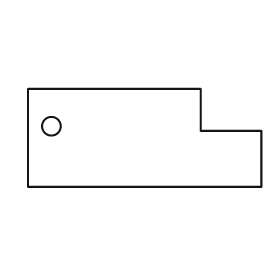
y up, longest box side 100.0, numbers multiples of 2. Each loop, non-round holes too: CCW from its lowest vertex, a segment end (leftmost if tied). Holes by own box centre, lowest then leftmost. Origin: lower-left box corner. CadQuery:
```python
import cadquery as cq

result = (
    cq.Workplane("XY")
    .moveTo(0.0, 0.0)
    .lineTo(100.0, 0.0)
    .lineTo(100.0, 24.0)
    .lineTo(74.0, 24.0)
    .lineTo(74.0, 42.0)
    .lineTo(0.0, 42.0)
    .close()
    .moveTo(10.0, 26.0)
    .circle(4.0)
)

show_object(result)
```